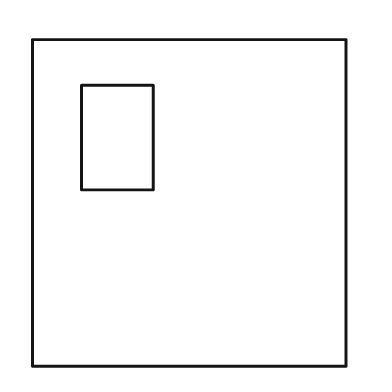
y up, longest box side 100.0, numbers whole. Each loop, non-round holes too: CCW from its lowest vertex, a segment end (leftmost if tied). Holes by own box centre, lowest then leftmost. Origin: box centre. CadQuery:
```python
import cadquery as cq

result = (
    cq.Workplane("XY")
    .moveTo(-48.0, -50.0)
    .lineTo(48.0, -50.0)
    .lineTo(48.0, 50.0)
    .lineTo(-48.0, 50.0)
    .close()
    .moveTo(-33.0, 4.0)
    .lineTo(-11.0, 4.0)
    .lineTo(-11.0, 36.0)
    .lineTo(-33.0, 36.0)
    .close()
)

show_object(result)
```